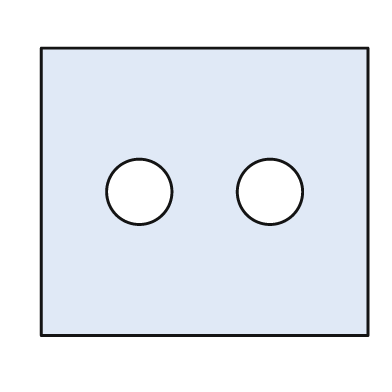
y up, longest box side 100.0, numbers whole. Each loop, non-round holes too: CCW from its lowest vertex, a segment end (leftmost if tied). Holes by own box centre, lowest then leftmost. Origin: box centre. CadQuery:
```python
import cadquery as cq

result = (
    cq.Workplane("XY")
    .moveTo(-50.0, -44.0)
    .lineTo(50.0, -44.0)
    .lineTo(50.0, 44.0)
    .lineTo(-50.0, 44.0)
    .close()
    .moveTo(-20.0, 0.0)
    .circle(10.0)
    .moveTo(20.0, 0.0)
    .circle(10.0)
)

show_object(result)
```